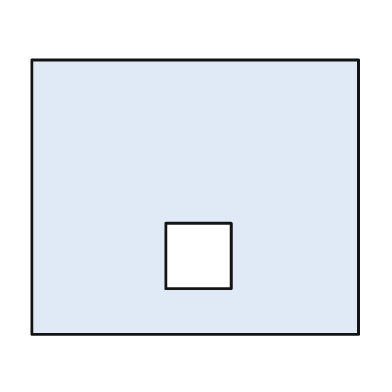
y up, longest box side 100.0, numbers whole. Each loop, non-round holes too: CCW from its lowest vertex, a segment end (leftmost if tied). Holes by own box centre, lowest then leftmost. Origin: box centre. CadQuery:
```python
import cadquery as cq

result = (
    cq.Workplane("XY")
    .moveTo(-50.0, -42.0)
    .lineTo(50.0, -42.0)
    .lineTo(50.0, 42.0)
    .lineTo(-50.0, 42.0)
    .close()
    .moveTo(-9.0, -28.0)
    .lineTo(11.0, -28.0)
    .lineTo(11.0, -8.0)
    .lineTo(-9.0, -8.0)
    .close()
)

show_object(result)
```